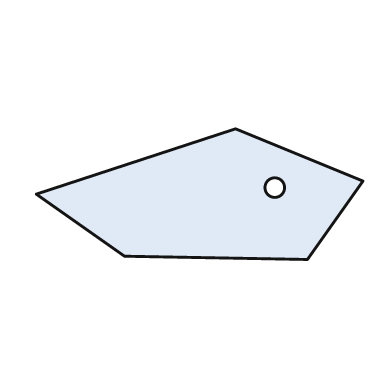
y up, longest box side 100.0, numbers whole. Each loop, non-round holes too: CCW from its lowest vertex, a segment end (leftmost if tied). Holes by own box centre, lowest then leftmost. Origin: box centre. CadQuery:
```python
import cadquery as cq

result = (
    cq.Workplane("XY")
    .moveTo(33.0, -20.0)
    .lineTo(50.0, 4.0)
    .lineTo(11.0, 20.0)
    .lineTo(-50.0, 0.0)
    .lineTo(-23.0, -19.0)
    .close()
    .moveTo(23.0, 2.0)
    .circle(3.0)
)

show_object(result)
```